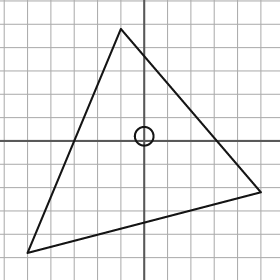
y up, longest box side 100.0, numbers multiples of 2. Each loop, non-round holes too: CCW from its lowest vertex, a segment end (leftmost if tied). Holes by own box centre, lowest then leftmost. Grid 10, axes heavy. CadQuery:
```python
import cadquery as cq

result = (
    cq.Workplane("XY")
    .moveTo(-50.0, -48.0)
    .lineTo(50.0, -22.0)
    .lineTo(-10.0, 48.0)
    .close()
    .moveTo(0.0, 2.0)
    .circle(4.0)
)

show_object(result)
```